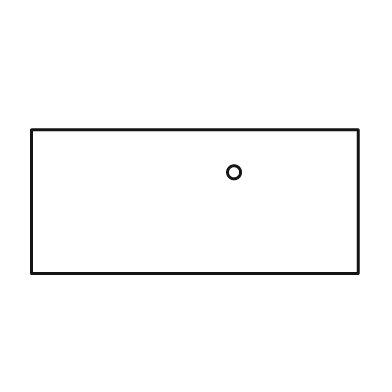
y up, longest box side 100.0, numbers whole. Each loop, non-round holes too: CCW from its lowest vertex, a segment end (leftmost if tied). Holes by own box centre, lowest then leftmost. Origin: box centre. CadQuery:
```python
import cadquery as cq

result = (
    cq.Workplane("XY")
    .moveTo(-50.0, -22.0)
    .lineTo(50.0, -22.0)
    .lineTo(50.0, 22.0)
    .lineTo(-50.0, 22.0)
    .close()
    .moveTo(12.0, 9.0)
    .circle(2.0)
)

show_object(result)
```